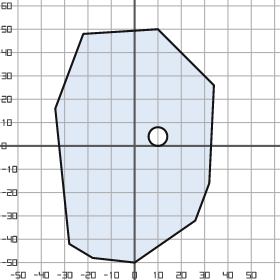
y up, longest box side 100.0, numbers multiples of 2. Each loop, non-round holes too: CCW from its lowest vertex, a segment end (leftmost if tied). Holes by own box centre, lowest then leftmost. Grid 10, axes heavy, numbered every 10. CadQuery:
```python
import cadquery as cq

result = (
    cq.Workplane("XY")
    .moveTo(0.0, -50.0)
    .lineTo(26.0, -32.0)
    .lineTo(32.0, -16.0)
    .lineTo(34.0, 26.0)
    .lineTo(10.0, 50.0)
    .lineTo(-22.0, 48.0)
    .lineTo(-34.0, 16.0)
    .lineTo(-28.0, -42.0)
    .lineTo(-18.0, -48.0)
    .close()
    .moveTo(10.0, 4.0)
    .circle(4.0)
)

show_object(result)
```